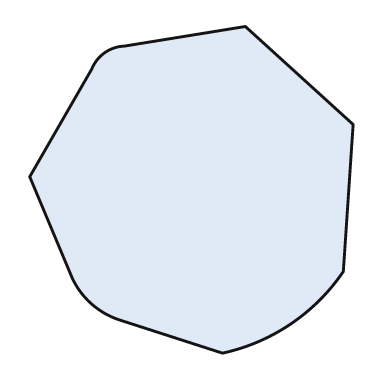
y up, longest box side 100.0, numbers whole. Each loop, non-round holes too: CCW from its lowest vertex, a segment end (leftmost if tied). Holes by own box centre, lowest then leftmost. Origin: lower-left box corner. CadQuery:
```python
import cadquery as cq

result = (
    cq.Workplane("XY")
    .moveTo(59.0, 0.0)
    .threePointArc((80.0, 9.0), (96.0, 25.0))
    .lineTo(99.0, 70.0)
    .lineTo(66.0, 100.0)
    .lineTo(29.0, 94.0)
    .threePointArc((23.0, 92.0), (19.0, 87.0))
    .lineTo(0.0, 54.0)
    .lineTo(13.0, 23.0)
    .threePointArc((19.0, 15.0), (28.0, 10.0))
    .close()
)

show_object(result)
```